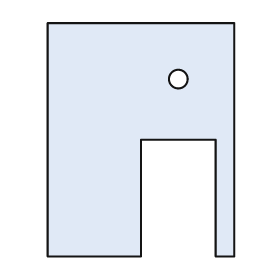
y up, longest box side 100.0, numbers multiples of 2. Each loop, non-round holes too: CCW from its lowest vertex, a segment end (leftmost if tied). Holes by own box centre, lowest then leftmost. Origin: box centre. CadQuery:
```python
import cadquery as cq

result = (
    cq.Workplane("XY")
    .moveTo(-40.0, -50.0)
    .lineTo(0.0, -50.0)
    .lineTo(0.0, 0.0)
    .lineTo(32.0, 0.0)
    .lineTo(32.0, -50.0)
    .lineTo(40.0, -50.0)
    .lineTo(40.0, 50.0)
    .lineTo(-40.0, 50.0)
    .close()
    .moveTo(16.0, 26.0)
    .circle(4.0)
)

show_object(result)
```